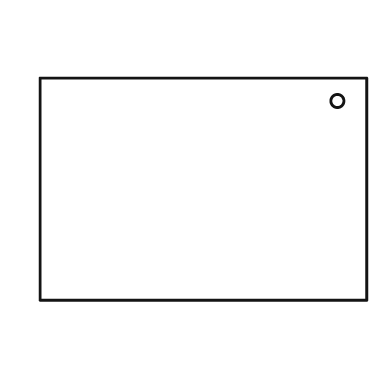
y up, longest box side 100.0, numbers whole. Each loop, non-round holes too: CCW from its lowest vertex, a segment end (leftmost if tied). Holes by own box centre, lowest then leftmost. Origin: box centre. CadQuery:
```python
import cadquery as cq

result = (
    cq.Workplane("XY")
    .moveTo(-50.0, -34.0)
    .lineTo(50.0, -34.0)
    .lineTo(50.0, 34.0)
    .lineTo(-50.0, 34.0)
    .close()
    .moveTo(41.0, 27.0)
    .circle(2.0)
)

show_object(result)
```